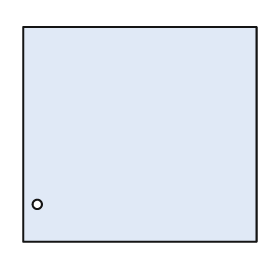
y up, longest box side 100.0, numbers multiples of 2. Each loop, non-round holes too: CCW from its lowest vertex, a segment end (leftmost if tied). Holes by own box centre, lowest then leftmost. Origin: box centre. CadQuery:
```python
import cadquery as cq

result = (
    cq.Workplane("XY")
    .moveTo(-50.0, -46.0)
    .lineTo(50.0, -46.0)
    .lineTo(50.0, 46.0)
    .lineTo(-50.0, 46.0)
    .close()
    .moveTo(-44.0, -30.0)
    .circle(2.0)
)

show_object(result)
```